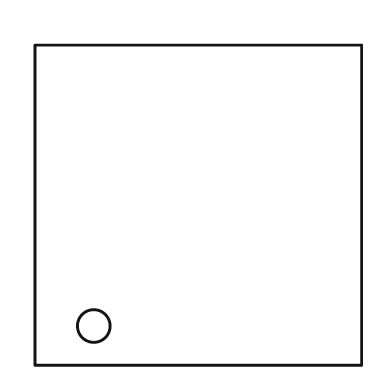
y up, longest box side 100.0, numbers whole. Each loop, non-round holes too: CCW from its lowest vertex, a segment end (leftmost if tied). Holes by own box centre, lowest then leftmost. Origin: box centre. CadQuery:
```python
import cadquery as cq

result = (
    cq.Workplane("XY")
    .moveTo(-50.0, -49.0)
    .lineTo(50.0, -49.0)
    .lineTo(50.0, 49.0)
    .lineTo(-50.0, 49.0)
    .close()
    .moveTo(-32.0, -37.0)
    .circle(5.0)
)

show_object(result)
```